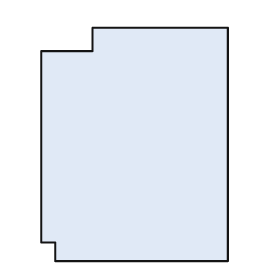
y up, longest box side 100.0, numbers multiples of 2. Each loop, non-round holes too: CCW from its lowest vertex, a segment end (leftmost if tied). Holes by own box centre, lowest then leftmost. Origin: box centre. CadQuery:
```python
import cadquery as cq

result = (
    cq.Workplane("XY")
    .moveTo(-34.0, -50.0)
    .lineTo(40.0, -50.0)
    .lineTo(40.0, 50.0)
    .lineTo(-18.0, 50.0)
    .lineTo(-18.0, 40.0)
    .lineTo(-40.0, 40.0)
    .lineTo(-40.0, -42.0)
    .lineTo(-34.0, -42.0)
    .close()
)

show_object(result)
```